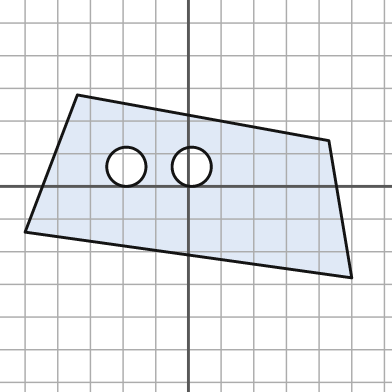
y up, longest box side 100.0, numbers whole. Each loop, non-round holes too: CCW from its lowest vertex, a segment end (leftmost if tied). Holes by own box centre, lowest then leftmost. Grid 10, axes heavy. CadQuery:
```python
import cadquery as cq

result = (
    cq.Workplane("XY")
    .moveTo(50.0, -28.0)
    .lineTo(43.0, 14.0)
    .lineTo(-34.0, 28.0)
    .lineTo(-50.0, -14.0)
    .close()
    .moveTo(-19.0, 6.0)
    .circle(6.0)
    .moveTo(1.0, 6.0)
    .circle(6.0)
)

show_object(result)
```